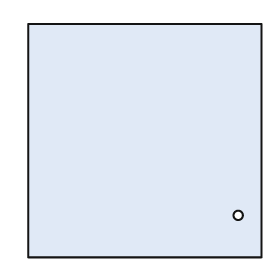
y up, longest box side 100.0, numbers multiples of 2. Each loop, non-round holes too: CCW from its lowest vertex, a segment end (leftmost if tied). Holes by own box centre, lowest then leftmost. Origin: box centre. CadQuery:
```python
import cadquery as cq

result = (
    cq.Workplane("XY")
    .moveTo(-50.0, -50.0)
    .lineTo(50.0, -50.0)
    .lineTo(50.0, 50.0)
    .lineTo(-50.0, 50.0)
    .close()
    .moveTo(40.0, -32.0)
    .circle(2.0)
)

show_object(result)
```